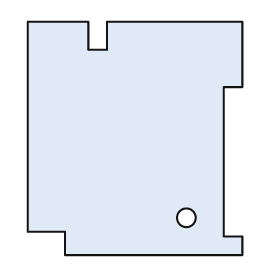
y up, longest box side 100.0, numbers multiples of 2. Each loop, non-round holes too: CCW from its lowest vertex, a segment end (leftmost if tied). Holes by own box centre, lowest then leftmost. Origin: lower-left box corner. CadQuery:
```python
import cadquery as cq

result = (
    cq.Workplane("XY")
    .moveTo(16.0, 0.0)
    .lineTo(92.0, 0.0)
    .lineTo(92.0, 8.0)
    .lineTo(84.0, 8.0)
    .lineTo(84.0, 72.0)
    .lineTo(92.0, 72.0)
    .lineTo(92.0, 100.0)
    .lineTo(34.0, 100.0)
    .lineTo(34.0, 88.0)
    .lineTo(26.0, 88.0)
    .lineTo(26.0, 100.0)
    .lineTo(0.0, 100.0)
    .lineTo(0.0, 10.0)
    .lineTo(16.0, 10.0)
    .close()
    .moveTo(68.0, 16.0)
    .circle(4.0)
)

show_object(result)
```